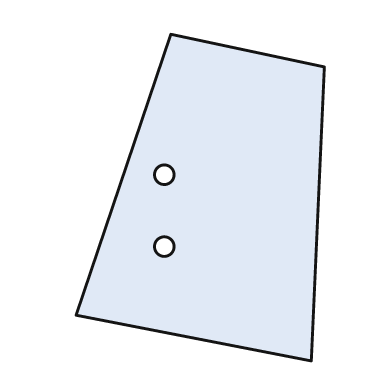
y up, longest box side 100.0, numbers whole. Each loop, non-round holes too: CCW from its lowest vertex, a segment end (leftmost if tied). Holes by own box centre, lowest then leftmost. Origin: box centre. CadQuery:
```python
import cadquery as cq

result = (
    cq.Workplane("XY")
    .moveTo(34.0, -50.0)
    .lineTo(38.0, 40.0)
    .lineTo(-9.0, 50.0)
    .lineTo(-38.0, -36.0)
    .close()
    .moveTo(-11.0, -15.0)
    .circle(3.0)
    .moveTo(-11.0, 7.0)
    .circle(3.0)
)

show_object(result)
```